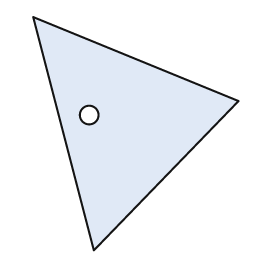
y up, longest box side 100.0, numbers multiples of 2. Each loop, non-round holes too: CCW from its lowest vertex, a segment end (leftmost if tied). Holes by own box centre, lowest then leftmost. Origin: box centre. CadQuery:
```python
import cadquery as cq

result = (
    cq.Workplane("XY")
    .moveTo(-18.0, -50.0)
    .lineTo(44.0, 14.0)
    .lineTo(-44.0, 50.0)
    .close()
    .moveTo(-20.0, 8.0)
    .circle(4.0)
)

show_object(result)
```